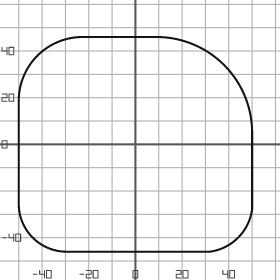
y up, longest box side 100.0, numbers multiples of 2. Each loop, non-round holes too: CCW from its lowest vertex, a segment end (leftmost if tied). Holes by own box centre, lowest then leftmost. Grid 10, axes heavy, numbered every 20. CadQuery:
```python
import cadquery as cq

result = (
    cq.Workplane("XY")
    .moveTo(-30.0, -46.0)
    .lineTo(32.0, -46.0)
    .threePointArc((44.0, -40.0), (50.0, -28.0))
    .lineTo(50.0, 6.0)
    .threePointArc((38.0, 34.0), (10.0, 46.0))
    .lineTo(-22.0, 46.0)
    .threePointArc((-42.0, 38.0), (-50.0, 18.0))
    .lineTo(-50.0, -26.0)
    .threePointArc((-44.0, -40.0), (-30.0, -46.0))
    .close()
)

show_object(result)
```